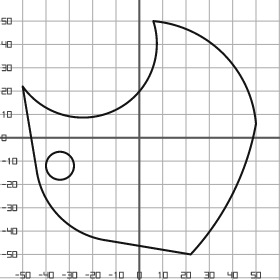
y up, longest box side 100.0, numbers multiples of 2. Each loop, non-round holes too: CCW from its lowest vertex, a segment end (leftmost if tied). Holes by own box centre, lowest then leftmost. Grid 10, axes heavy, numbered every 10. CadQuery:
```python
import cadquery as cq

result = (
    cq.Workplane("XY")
    .moveTo(22.0, -50.0)
    .threePointArc((40.0, -24.0), (50.0, 6.0))
    .threePointArc((36.0, 36.0), (6.0, 50.0))
    .threePointArc((-10.0, 12.0), (-50.0, 22.0))
    .lineTo(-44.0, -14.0)
    .threePointArc((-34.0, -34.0), (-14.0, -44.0))
    .close()
    .moveTo(-34.0, -12.0)
    .circle(6.0)
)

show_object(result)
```